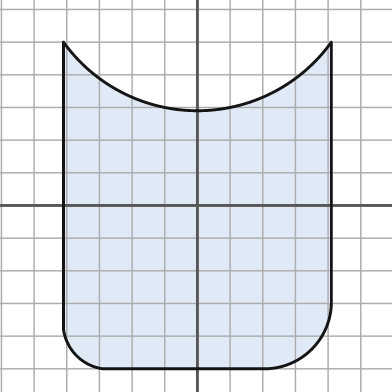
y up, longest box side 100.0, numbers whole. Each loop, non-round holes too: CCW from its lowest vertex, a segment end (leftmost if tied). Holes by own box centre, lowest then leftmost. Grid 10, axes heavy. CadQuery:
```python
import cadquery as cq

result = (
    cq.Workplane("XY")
    .moveTo(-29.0, -50.0)
    .lineTo(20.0, -50.0)
    .threePointArc((35.0, -44.0), (41.0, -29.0))
    .lineTo(41.0, 50.0)
    .threePointArc((0.0, 29.0), (-41.0, 50.0))
    .lineTo(-41.0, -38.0)
    .threePointArc((-37.0, -46.0), (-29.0, -50.0))
    .close()
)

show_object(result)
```